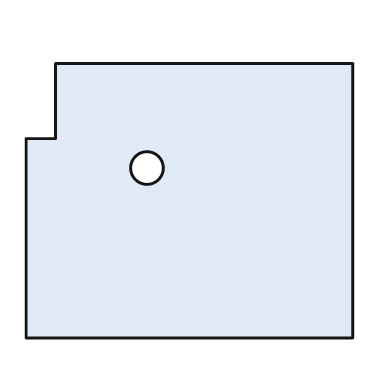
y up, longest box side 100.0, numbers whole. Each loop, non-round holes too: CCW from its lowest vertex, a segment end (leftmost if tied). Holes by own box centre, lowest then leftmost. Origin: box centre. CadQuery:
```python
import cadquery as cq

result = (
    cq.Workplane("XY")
    .moveTo(-50.0, -42.0)
    .lineTo(50.0, -42.0)
    .lineTo(50.0, 42.0)
    .lineTo(-41.0, 42.0)
    .lineTo(-41.0, 19.0)
    .lineTo(-50.0, 19.0)
    .close()
    .moveTo(-13.0, 10.0)
    .circle(5.0)
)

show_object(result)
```